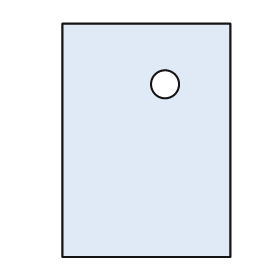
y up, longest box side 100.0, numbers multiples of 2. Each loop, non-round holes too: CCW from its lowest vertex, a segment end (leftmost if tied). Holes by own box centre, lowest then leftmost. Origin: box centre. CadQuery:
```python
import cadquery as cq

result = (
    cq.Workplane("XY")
    .moveTo(-36.0, -50.0)
    .lineTo(36.0, -50.0)
    .lineTo(36.0, 50.0)
    .lineTo(-36.0, 50.0)
    .close()
    .moveTo(8.0, 24.0)
    .circle(6.0)
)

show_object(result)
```